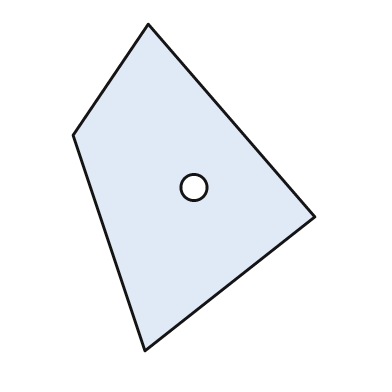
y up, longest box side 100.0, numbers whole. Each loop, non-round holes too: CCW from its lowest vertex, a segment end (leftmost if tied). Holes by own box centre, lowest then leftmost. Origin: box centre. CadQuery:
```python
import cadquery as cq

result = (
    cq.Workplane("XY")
    .moveTo(-15.0, -50.0)
    .lineTo(37.0, -9.0)
    .lineTo(-14.0, 50.0)
    .lineTo(-37.0, 16.0)
    .close()
    .moveTo(0.0, 0.0)
    .circle(4.0)
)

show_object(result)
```